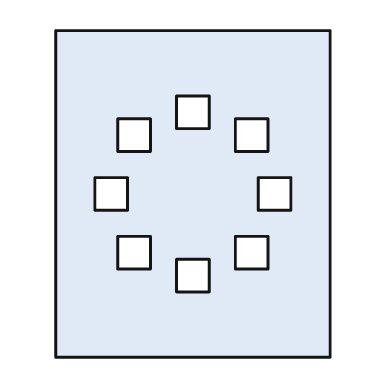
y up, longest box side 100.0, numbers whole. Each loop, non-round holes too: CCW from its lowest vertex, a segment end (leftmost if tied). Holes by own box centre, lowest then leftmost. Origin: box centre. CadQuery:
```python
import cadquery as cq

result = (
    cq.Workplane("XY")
    .moveTo(-42.0, -50.0)
    .lineTo(42.0, -50.0)
    .lineTo(42.0, 50.0)
    .lineTo(-42.0, 50.0)
    .close()
    .moveTo(-5.0, -30.0)
    .lineTo(5.0, -30.0)
    .lineTo(5.0, -20.0)
    .lineTo(-5.0, -20.0)
    .close()
    .moveTo(-23.0, -23.0)
    .lineTo(-13.0, -23.0)
    .lineTo(-13.0, -13.0)
    .lineTo(-23.0, -13.0)
    .close()
    .moveTo(13.0, -23.0)
    .lineTo(23.0, -23.0)
    .lineTo(23.0, -13.0)
    .lineTo(13.0, -13.0)
    .close()
    .moveTo(-30.0, -5.0)
    .lineTo(-20.0, -5.0)
    .lineTo(-20.0, 5.0)
    .lineTo(-30.0, 5.0)
    .close()
    .moveTo(20.0, -5.0)
    .lineTo(30.0, -5.0)
    .lineTo(30.0, 5.0)
    .lineTo(20.0, 5.0)
    .close()
    .moveTo(-23.0, 13.0)
    .lineTo(-13.0, 13.0)
    .lineTo(-13.0, 23.0)
    .lineTo(-23.0, 23.0)
    .close()
    .moveTo(13.0, 13.0)
    .lineTo(23.0, 13.0)
    .lineTo(23.0, 23.0)
    .lineTo(13.0, 23.0)
    .close()
    .moveTo(-5.0, 20.0)
    .lineTo(5.0, 20.0)
    .lineTo(5.0, 30.0)
    .lineTo(-5.0, 30.0)
    .close()
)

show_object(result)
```